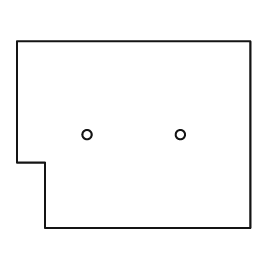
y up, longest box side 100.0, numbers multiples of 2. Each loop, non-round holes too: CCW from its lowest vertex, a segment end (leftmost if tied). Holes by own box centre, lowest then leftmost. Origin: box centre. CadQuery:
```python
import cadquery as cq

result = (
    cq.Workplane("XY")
    .moveTo(-38.0, -40.0)
    .lineTo(50.0, -40.0)
    .lineTo(50.0, 40.0)
    .lineTo(-50.0, 40.0)
    .lineTo(-50.0, -12.0)
    .lineTo(-38.0, -12.0)
    .close()
    .moveTo(-20.0, 0.0)
    .circle(2.0)
    .moveTo(20.0, 0.0)
    .circle(2.0)
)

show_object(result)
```